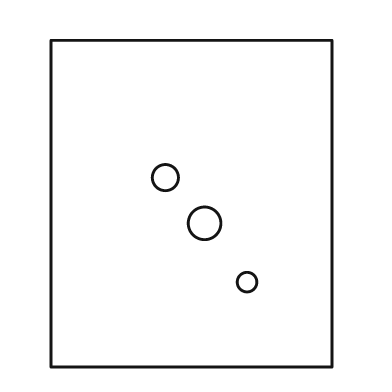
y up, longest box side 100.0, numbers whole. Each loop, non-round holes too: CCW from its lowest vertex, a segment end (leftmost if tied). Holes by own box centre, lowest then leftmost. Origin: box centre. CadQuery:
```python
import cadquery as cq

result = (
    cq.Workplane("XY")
    .moveTo(-43.0, -50.0)
    .lineTo(43.0, -50.0)
    .lineTo(43.0, 50.0)
    .lineTo(-43.0, 50.0)
    .close()
    .moveTo(17.0, -24.0)
    .circle(3.0)
    .moveTo(4.0, -6.0)
    .circle(5.0)
    .moveTo(-8.0, 8.0)
    .circle(4.0)
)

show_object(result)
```